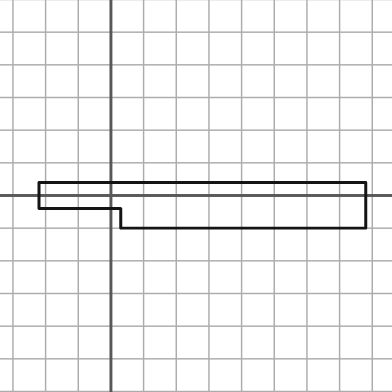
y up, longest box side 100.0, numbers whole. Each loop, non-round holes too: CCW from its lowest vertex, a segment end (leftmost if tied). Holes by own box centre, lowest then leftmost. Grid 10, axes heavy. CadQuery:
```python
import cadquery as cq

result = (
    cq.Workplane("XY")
    .moveTo(3.0, -10.0)
    .lineTo(78.0, -10.0)
    .lineTo(78.0, 4.0)
    .lineTo(-22.0, 4.0)
    .lineTo(-22.0, -4.0)
    .lineTo(3.0, -4.0)
    .close()
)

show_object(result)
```